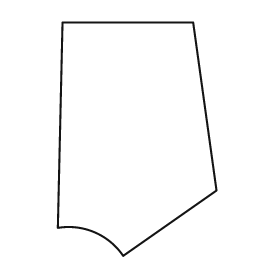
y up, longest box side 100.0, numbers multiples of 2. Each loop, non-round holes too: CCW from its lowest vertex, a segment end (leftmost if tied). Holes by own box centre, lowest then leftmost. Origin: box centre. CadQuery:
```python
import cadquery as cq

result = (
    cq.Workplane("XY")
    .moveTo(-6.0, -50.0)
    .lineTo(34.0, -22.0)
    .lineTo(24.0, 50.0)
    .lineTo(-32.0, 50.0)
    .lineTo(-34.0, -38.0)
    .threePointArc((-18.0, -40.0), (-6.0, -50.0))
    .close()
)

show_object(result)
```